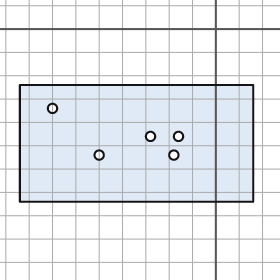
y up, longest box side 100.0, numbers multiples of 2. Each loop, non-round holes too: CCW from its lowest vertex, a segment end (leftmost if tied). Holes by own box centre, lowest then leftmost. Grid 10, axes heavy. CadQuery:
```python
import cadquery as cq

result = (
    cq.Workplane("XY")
    .moveTo(-84.0, -74.0)
    .lineTo(16.0, -74.0)
    .lineTo(16.0, -24.0)
    .lineTo(-84.0, -24.0)
    .close()
    .moveTo(-50.0, -54.0)
    .circle(2.0)
    .moveTo(-18.0, -54.0)
    .circle(2.0)
    .moveTo(-28.0, -46.0)
    .circle(2.0)
    .moveTo(-16.0, -46.0)
    .circle(2.0)
    .moveTo(-70.0, -34.0)
    .circle(2.0)
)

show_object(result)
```